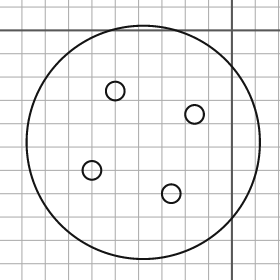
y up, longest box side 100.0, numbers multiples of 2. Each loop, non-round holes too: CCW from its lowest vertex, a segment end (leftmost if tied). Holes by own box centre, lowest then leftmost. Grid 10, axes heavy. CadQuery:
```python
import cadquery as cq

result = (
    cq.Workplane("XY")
    .moveTo(-38.0, -48.0)
    .circle(50.0)
    .moveTo(-26.0, -70.0)
    .circle(4.0)
    .moveTo(-60.0, -60.0)
    .circle(4.0)
    .moveTo(-16.0, -36.0)
    .circle(4.0)
    .moveTo(-50.0, -26.0)
    .circle(4.0)
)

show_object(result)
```